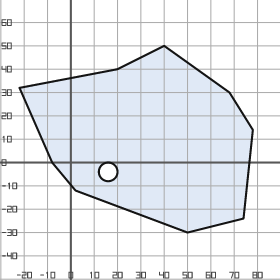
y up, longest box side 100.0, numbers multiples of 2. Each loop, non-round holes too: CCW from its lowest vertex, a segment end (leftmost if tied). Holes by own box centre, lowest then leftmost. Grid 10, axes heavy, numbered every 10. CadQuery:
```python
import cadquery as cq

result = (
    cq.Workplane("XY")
    .moveTo(50.0, -30.0)
    .lineTo(74.0, -24.0)
    .lineTo(78.0, 14.0)
    .lineTo(68.0, 30.0)
    .lineTo(40.0, 50.0)
    .lineTo(20.0, 40.0)
    .lineTo(-22.0, 32.0)
    .lineTo(-8.0, 0.0)
    .lineTo(2.0, -12.0)
    .close()
    .moveTo(16.0, -4.0)
    .circle(4.0)
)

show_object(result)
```